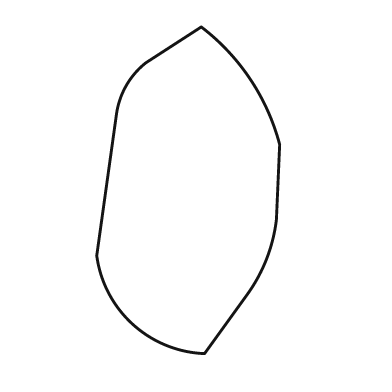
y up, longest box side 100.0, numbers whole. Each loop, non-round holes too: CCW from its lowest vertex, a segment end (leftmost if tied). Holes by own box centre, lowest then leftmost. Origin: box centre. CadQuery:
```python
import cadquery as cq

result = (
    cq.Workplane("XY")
    .moveTo(5.0, -50.0)
    .lineTo(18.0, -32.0)
    .threePointArc((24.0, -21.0), (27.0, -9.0))
    .lineTo(28.0, 14.0)
    .threePointArc((19.0, 34.0), (4.0, 50.0))
    .lineTo(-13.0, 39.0)
    .threePointArc((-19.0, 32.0), (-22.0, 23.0))
    .lineTo(-28.0, -20.0)
    .threePointArc((-17.0, -41.0), (5.0, -50.0))
    .close()
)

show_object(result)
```